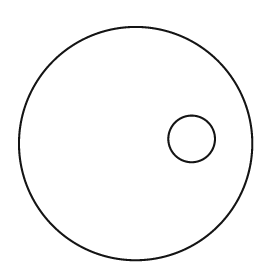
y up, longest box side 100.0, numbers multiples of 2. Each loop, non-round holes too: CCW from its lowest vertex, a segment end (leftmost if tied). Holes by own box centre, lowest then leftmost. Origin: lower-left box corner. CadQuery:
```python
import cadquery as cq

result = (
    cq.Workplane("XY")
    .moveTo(50.0, 50.0)
    .circle(50.0)
    .moveTo(74.0, 52.0)
    .circle(10.0)
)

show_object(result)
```